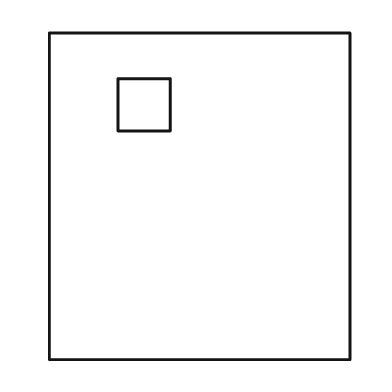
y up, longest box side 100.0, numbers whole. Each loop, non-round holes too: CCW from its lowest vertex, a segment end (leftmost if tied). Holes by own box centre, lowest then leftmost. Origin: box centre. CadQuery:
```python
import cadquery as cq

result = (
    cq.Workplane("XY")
    .moveTo(-46.0, -50.0)
    .lineTo(46.0, -50.0)
    .lineTo(46.0, 50.0)
    .lineTo(-46.0, 50.0)
    .close()
    .moveTo(-25.0, 20.0)
    .lineTo(-9.0, 20.0)
    .lineTo(-9.0, 36.0)
    .lineTo(-25.0, 36.0)
    .close()
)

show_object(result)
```